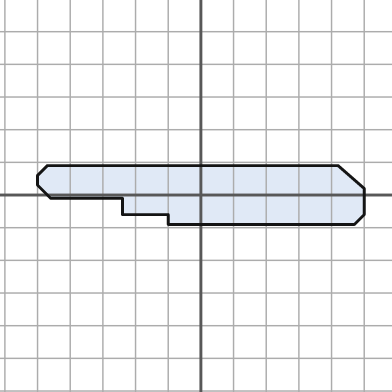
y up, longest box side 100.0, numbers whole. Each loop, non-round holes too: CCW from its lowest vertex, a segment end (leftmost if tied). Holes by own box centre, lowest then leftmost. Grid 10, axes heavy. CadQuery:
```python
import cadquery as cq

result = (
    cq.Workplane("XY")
    .moveTo(-10.0, -9.0)
    .lineTo(47.0, -9.0)
    .lineTo(50.0, -6.0)
    .lineTo(50.0, 2.0)
    .lineTo(42.0, 9.0)
    .lineTo(-47.0, 9.0)
    .lineTo(-50.0, 6.0)
    .lineTo(-50.0, 3.0)
    .lineTo(-46.0, -1.0)
    .lineTo(-24.0, -1.0)
    .lineTo(-24.0, -6.0)
    .lineTo(-10.0, -6.0)
    .close()
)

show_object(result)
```